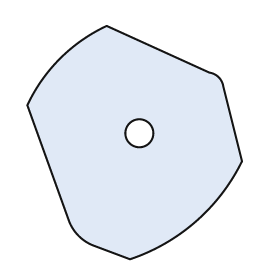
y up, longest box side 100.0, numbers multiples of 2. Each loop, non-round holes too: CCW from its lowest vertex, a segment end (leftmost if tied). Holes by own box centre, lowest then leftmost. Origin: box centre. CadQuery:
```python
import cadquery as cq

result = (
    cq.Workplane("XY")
    .moveTo(-2.0, -50.0)
    .threePointArc((26.0, -34.0), (46.0, -8.0))
    .lineTo(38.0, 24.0)
    .threePointArc((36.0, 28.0), (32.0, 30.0))
    .lineTo(-12.0, 50.0)
    .threePointArc((-32.0, 36.0), (-46.0, 16.0))
    .lineTo(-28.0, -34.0)
    .threePointArc((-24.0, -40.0), (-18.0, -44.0))
    .close()
    .moveTo(2.0, 4.0)
    .circle(6.0)
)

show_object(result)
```